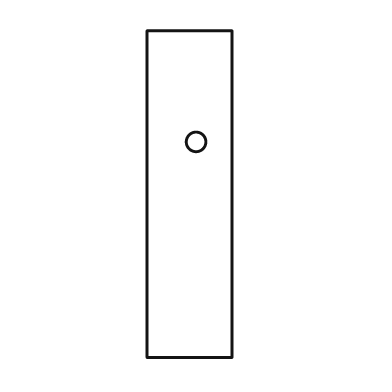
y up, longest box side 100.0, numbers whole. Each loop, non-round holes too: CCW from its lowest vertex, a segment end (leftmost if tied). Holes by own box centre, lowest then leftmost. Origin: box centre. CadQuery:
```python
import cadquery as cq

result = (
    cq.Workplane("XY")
    .moveTo(-13.0, -50.0)
    .lineTo(13.0, -50.0)
    .lineTo(13.0, 50.0)
    .lineTo(-13.0, 50.0)
    .close()
    .moveTo(2.0, 16.0)
    .circle(3.0)
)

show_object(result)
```